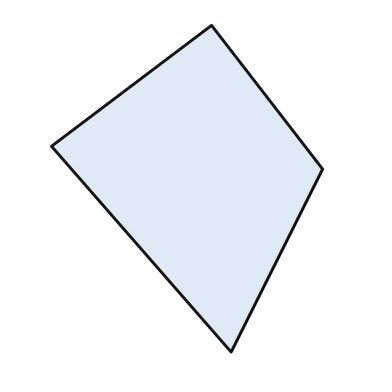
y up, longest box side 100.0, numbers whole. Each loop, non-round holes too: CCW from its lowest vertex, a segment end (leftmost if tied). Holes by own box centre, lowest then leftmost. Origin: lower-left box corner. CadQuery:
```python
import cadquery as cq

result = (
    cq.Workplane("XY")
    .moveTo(55.0, 0.0)
    .lineTo(83.0, 56.0)
    .lineTo(49.0, 100.0)
    .lineTo(0.0, 63.0)
    .close()
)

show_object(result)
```